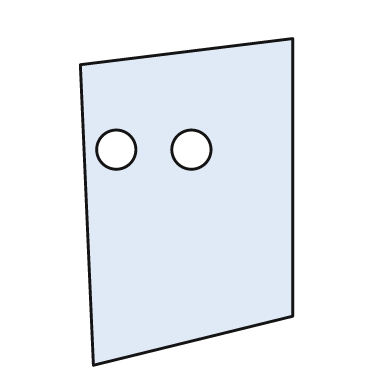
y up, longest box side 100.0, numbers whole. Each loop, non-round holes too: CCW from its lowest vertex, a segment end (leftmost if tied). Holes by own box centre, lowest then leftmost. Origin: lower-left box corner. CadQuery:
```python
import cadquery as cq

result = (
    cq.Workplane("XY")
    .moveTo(4.0, 0.0)
    .lineTo(65.0, 15.0)
    .lineTo(65.0, 100.0)
    .lineTo(0.0, 92.0)
    .close()
    .moveTo(11.0, 66.0)
    .circle(6.0)
    .moveTo(34.0, 66.0)
    .circle(6.0)
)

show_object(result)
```